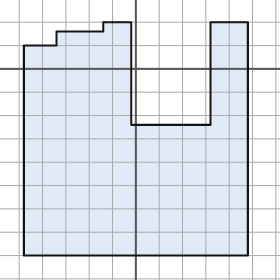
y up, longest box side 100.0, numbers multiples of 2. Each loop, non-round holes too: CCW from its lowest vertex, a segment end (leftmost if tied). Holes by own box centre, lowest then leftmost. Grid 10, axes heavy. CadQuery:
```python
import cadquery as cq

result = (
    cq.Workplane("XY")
    .moveTo(-48.0, -80.0)
    .lineTo(48.0, -80.0)
    .lineTo(48.0, 20.0)
    .lineTo(32.0, 20.0)
    .lineTo(32.0, -24.0)
    .lineTo(-2.0, -24.0)
    .lineTo(-2.0, 20.0)
    .lineTo(-14.0, 20.0)
    .lineTo(-14.0, 16.0)
    .lineTo(-34.0, 16.0)
    .lineTo(-34.0, 10.0)
    .lineTo(-48.0, 10.0)
    .close()
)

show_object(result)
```